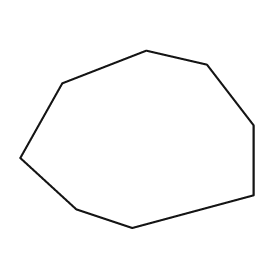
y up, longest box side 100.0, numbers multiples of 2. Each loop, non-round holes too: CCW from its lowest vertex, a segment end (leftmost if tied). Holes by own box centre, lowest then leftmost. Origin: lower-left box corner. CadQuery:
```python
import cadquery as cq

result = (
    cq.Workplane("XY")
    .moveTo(48.0, 0.0)
    .lineTo(100.0, 14.0)
    .lineTo(100.0, 44.0)
    .lineTo(80.0, 70.0)
    .lineTo(54.0, 76.0)
    .lineTo(18.0, 62.0)
    .lineTo(0.0, 30.0)
    .lineTo(24.0, 8.0)
    .close()
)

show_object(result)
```